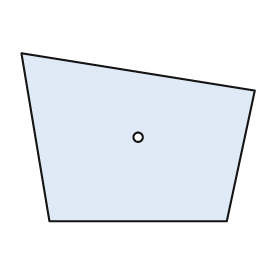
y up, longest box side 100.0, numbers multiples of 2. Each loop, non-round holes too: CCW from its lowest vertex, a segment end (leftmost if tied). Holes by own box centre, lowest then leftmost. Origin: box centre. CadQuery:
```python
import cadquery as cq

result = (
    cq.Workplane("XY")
    .moveTo(-38.0, -36.0)
    .lineTo(38.0, -36.0)
    .lineTo(50.0, 20.0)
    .lineTo(-50.0, 36.0)
    .close()
    .moveTo(0.0, 0.0)
    .circle(2.0)
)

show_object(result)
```